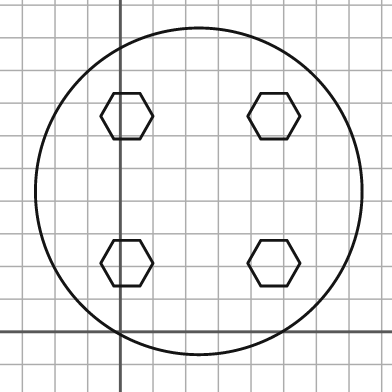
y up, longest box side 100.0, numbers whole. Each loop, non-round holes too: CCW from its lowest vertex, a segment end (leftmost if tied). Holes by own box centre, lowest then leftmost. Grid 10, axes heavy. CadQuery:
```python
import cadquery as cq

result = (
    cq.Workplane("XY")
    .moveTo(24.0, 43.0)
    .circle(50.0)
    .moveTo(-2.0, 14.0)
    .lineTo(6.0, 14.0)
    .lineTo(10.0, 21.0)
    .lineTo(6.0, 28.0)
    .lineTo(-2.0, 28.0)
    .lineTo(-6.0, 21.0)
    .close()
    .moveTo(43.0, 14.0)
    .lineTo(51.0, 14.0)
    .lineTo(55.0, 21.0)
    .lineTo(51.0, 28.0)
    .lineTo(43.0, 28.0)
    .lineTo(39.0, 21.0)
    .close()
    .moveTo(-2.0, 59.0)
    .lineTo(6.0, 59.0)
    .lineTo(10.0, 66.0)
    .lineTo(6.0, 73.0)
    .lineTo(-2.0, 73.0)
    .lineTo(-6.0, 66.0)
    .close()
    .moveTo(43.0, 59.0)
    .lineTo(51.0, 59.0)
    .lineTo(55.0, 66.0)
    .lineTo(51.0, 73.0)
    .lineTo(43.0, 73.0)
    .lineTo(39.0, 66.0)
    .close()
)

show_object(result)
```